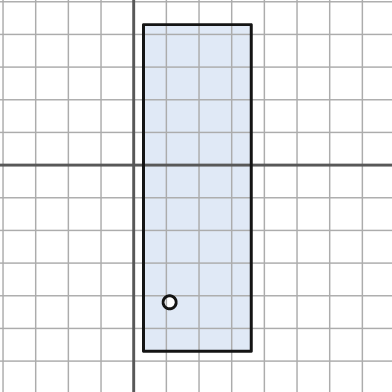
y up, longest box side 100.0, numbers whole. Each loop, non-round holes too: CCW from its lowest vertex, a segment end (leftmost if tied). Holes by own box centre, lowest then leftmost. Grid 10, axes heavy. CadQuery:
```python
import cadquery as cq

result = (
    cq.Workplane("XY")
    .moveTo(3.0, -57.0)
    .lineTo(36.0, -57.0)
    .lineTo(36.0, 43.0)
    .lineTo(3.0, 43.0)
    .close()
    .moveTo(11.0, -42.0)
    .circle(2.0)
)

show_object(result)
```